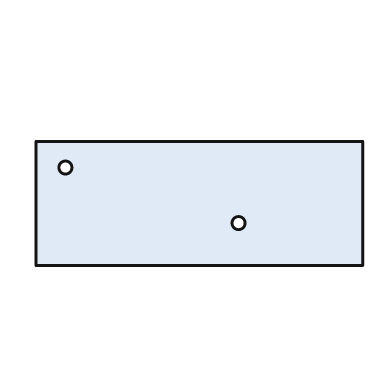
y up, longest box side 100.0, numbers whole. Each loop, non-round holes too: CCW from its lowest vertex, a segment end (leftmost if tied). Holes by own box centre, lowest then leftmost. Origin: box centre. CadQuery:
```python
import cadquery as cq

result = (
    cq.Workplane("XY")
    .moveTo(-50.0, -19.0)
    .lineTo(50.0, -19.0)
    .lineTo(50.0, 19.0)
    .lineTo(-50.0, 19.0)
    .close()
    .moveTo(12.0, -6.0)
    .circle(2.0)
    .moveTo(-41.0, 11.0)
    .circle(2.0)
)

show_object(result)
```